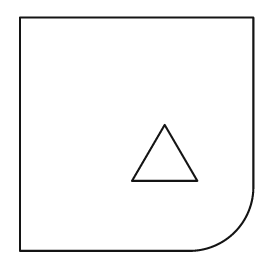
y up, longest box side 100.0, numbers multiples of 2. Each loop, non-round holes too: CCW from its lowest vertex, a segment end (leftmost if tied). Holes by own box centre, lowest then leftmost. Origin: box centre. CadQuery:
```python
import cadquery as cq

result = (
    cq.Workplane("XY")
    .moveTo(-50.0, -50.0)
    .lineTo(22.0, -50.0)
    .threePointArc((42.0, -42.0), (50.0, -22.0))
    .lineTo(50.0, 50.0)
    .lineTo(-50.0, 50.0)
    .close()
    .moveTo(-2.0, -20.0)
    .lineTo(26.0, -20.0)
    .lineTo(12.0, 4.0)
    .close()
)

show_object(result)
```